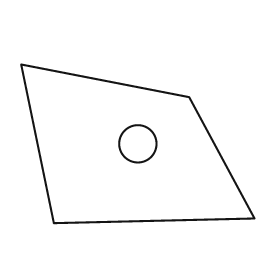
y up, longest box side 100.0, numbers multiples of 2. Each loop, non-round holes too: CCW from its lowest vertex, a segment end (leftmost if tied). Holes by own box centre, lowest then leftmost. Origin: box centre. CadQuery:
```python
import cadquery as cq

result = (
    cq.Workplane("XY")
    .moveTo(-36.0, -34.0)
    .lineTo(50.0, -32.0)
    .lineTo(22.0, 20.0)
    .lineTo(-50.0, 34.0)
    .close()
    .moveTo(0.0, 0.0)
    .circle(8.0)
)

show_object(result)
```